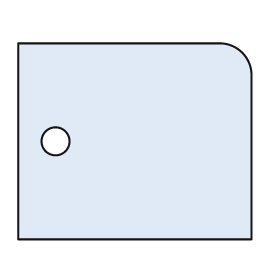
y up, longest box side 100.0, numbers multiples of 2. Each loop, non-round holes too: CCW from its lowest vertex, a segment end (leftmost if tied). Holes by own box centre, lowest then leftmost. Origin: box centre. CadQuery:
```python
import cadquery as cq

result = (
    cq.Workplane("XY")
    .moveTo(-50.0, -42.0)
    .lineTo(50.0, -42.0)
    .lineTo(50.0, 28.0)
    .threePointArc((46.0, 38.0), (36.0, 42.0))
    .lineTo(-50.0, 42.0)
    .close()
    .moveTo(-34.0, 0.0)
    .circle(6.0)
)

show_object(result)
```